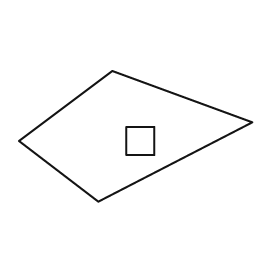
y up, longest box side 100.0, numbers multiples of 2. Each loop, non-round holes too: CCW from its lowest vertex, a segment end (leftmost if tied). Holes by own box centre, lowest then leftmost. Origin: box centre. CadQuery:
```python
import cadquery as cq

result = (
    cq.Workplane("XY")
    .moveTo(-16.0, -28.0)
    .lineTo(50.0, 6.0)
    .lineTo(-10.0, 28.0)
    .lineTo(-50.0, -2.0)
    .close()
    .moveTo(-4.0, -8.0)
    .lineTo(8.0, -8.0)
    .lineTo(8.0, 4.0)
    .lineTo(-4.0, 4.0)
    .close()
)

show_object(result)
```